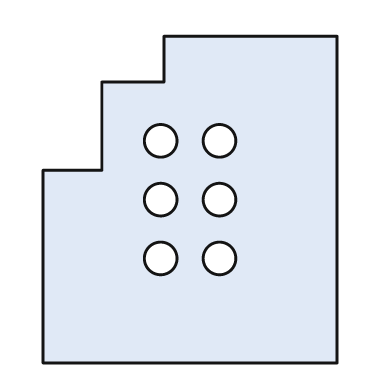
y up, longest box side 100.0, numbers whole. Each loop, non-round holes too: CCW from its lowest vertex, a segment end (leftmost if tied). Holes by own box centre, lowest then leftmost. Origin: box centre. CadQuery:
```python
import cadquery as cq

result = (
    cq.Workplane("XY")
    .moveTo(-45.0, -50.0)
    .lineTo(45.0, -50.0)
    .lineTo(45.0, 50.0)
    .lineTo(-8.0, 50.0)
    .lineTo(-8.0, 36.0)
    .lineTo(-27.0, 36.0)
    .lineTo(-27.0, 9.0)
    .lineTo(-45.0, 9.0)
    .close()
    .moveTo(-9.0, -18.0)
    .circle(5.0)
    .moveTo(9.0, -18.0)
    .circle(5.0)
    .moveTo(-9.0, 0.0)
    .circle(5.0)
    .moveTo(9.0, 0.0)
    .circle(5.0)
    .moveTo(-9.0, 18.0)
    .circle(5.0)
    .moveTo(9.0, 18.0)
    .circle(5.0)
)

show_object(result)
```